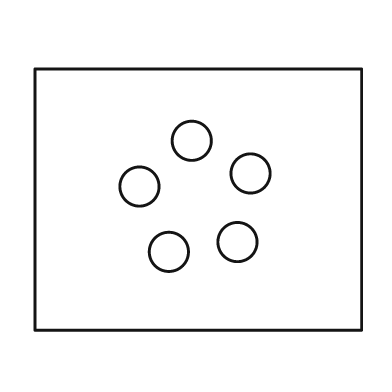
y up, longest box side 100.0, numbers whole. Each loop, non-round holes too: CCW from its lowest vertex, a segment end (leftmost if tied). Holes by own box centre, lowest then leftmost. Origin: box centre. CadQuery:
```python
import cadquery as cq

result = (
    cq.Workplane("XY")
    .moveTo(-50.0, -40.0)
    .lineTo(50.0, -40.0)
    .lineTo(50.0, 40.0)
    .lineTo(-50.0, 40.0)
    .close()
    .moveTo(-9.0, -16.0)
    .circle(6.0)
    .moveTo(12.0, -13.0)
    .circle(6.0)
    .moveTo(-18.0, 4.0)
    .circle(6.0)
    .moveTo(16.0, 8.0)
    .circle(6.0)
    .moveTo(-2.0, 18.0)
    .circle(6.0)
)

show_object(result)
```